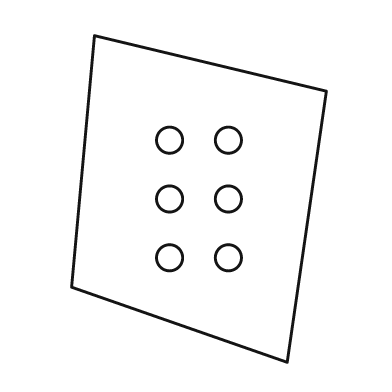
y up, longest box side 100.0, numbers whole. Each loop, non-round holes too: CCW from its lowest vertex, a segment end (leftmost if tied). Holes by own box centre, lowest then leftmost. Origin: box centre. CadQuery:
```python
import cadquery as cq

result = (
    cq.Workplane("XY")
    .moveTo(27.0, -50.0)
    .lineTo(39.0, 33.0)
    .lineTo(-32.0, 50.0)
    .lineTo(-39.0, -27.0)
    .close()
    .moveTo(-9.0, -18.0)
    .circle(4.0)
    .moveTo(9.0, -18.0)
    .circle(4.0)
    .moveTo(-9.0, 0.0)
    .circle(4.0)
    .moveTo(9.0, 0.0)
    .circle(4.0)
    .moveTo(-9.0, 18.0)
    .circle(4.0)
    .moveTo(9.0, 18.0)
    .circle(4.0)
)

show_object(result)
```